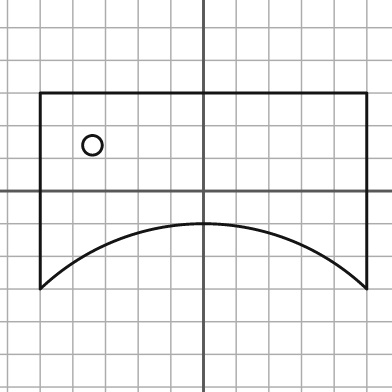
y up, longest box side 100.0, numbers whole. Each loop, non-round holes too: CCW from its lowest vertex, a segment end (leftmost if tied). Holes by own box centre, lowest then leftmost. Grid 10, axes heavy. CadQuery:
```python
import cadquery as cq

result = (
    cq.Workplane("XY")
    .moveTo(-50.0, -30.0)
    .threePointArc((0.0, -10.0), (50.0, -30.0))
    .lineTo(50.0, 30.0)
    .lineTo(-50.0, 30.0)
    .close()
    .moveTo(-34.0, 14.0)
    .circle(3.0)
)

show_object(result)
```